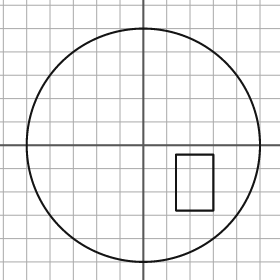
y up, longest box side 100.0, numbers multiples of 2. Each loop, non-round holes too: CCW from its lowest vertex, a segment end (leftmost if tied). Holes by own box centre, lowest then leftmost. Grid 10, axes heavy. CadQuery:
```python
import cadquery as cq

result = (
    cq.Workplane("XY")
    .moveTo(0.0, 0.0)
    .circle(50.0)
    .moveTo(14.0, -28.0)
    .lineTo(30.0, -28.0)
    .lineTo(30.0, -4.0)
    .lineTo(14.0, -4.0)
    .close()
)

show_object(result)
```